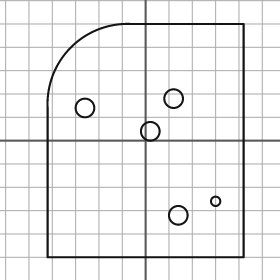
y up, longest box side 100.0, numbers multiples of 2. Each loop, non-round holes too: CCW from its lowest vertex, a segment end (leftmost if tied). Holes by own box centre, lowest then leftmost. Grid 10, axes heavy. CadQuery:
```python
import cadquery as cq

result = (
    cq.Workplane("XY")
    .moveTo(-42.0, -50.0)
    .lineTo(42.0, -50.0)
    .lineTo(42.0, 50.0)
    .lineTo(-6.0, 50.0)
    .threePointArc((-32.0, 40.0), (-42.0, 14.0))
    .close()
    .moveTo(14.0, -32.0)
    .circle(4.0)
    .moveTo(30.0, -26.0)
    .circle(2.0)
    .moveTo(2.0, 4.0)
    .circle(4.0)
    .moveTo(-26.0, 14.0)
    .circle(4.0)
    .moveTo(12.0, 18.0)
    .circle(4.0)
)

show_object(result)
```